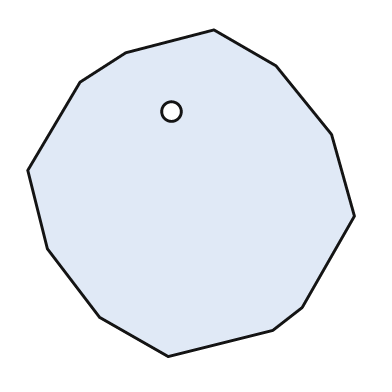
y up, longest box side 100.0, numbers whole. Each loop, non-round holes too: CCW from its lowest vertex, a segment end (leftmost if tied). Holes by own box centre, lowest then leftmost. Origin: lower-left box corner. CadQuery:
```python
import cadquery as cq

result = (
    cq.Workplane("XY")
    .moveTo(43.0, 0.0)
    .lineTo(75.0, 8.0)
    .lineTo(84.0, 15.0)
    .lineTo(100.0, 43.0)
    .lineTo(93.0, 68.0)
    .lineTo(76.0, 89.0)
    .lineTo(57.0, 100.0)
    .lineTo(30.0, 93.0)
    .lineTo(16.0, 84.0)
    .lineTo(0.0, 57.0)
    .lineTo(6.0, 33.0)
    .lineTo(22.0, 12.0)
    .close()
    .moveTo(44.0, 75.0)
    .circle(3.0)
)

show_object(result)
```